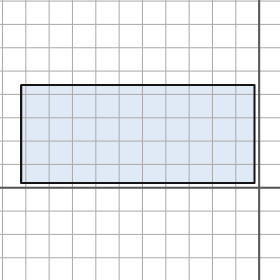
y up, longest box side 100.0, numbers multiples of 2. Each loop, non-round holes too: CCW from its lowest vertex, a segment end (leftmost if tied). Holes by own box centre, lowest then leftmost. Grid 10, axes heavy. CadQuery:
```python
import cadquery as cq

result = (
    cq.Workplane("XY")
    .moveTo(-102.0, 2.0)
    .lineTo(-2.0, 2.0)
    .lineTo(-2.0, 44.0)
    .lineTo(-102.0, 44.0)
    .close()
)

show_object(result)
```